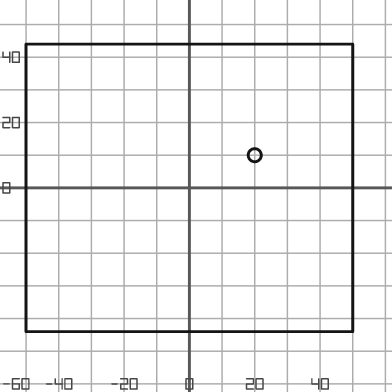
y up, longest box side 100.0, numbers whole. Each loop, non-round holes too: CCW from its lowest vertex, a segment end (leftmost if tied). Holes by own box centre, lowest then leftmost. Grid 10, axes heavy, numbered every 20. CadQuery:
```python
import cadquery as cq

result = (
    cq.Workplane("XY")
    .moveTo(-50.0, -44.0)
    .lineTo(50.0, -44.0)
    .lineTo(50.0, 44.0)
    .lineTo(-50.0, 44.0)
    .close()
    .moveTo(20.0, 10.0)
    .circle(2.0)
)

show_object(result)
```